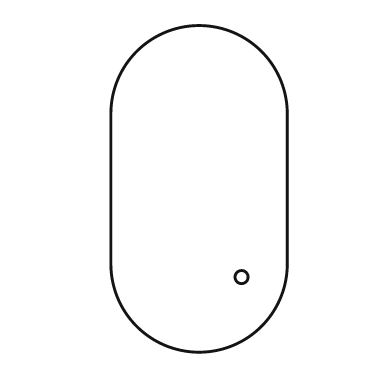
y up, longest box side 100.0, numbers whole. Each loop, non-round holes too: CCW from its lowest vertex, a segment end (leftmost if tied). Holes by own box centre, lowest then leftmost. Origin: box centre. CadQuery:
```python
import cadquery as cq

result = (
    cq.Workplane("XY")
    .moveTo(-27.0, -23.0)
    .threePointArc((0.0, -50.0), (27.0, -23.0))
    .lineTo(27.0, 23.0)
    .threePointArc((0.0, 50.0), (-27.0, 23.0))
    .close()
    .moveTo(13.0, -27.0)
    .circle(2.0)
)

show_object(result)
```